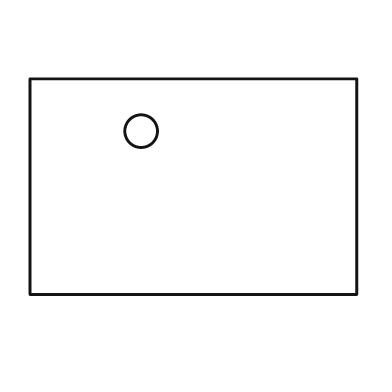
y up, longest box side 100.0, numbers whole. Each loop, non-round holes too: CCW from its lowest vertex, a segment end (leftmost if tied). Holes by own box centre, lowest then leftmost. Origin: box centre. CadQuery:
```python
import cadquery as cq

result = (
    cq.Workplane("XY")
    .moveTo(-50.0, -33.0)
    .lineTo(50.0, -33.0)
    .lineTo(50.0, 33.0)
    .lineTo(-50.0, 33.0)
    .close()
    .moveTo(-16.0, 17.0)
    .circle(5.0)
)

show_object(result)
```